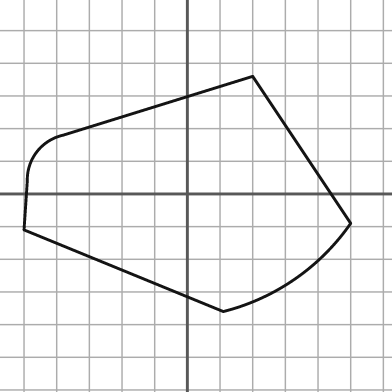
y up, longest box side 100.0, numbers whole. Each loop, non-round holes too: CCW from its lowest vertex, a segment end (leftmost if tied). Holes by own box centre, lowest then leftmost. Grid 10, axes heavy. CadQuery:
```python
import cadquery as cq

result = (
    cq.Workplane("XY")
    .moveTo(11.0, -36.0)
    .threePointArc((33.0, -26.0), (50.0, -9.0))
    .lineTo(20.0, 36.0)
    .lineTo(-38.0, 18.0)
    .threePointArc((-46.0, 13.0), (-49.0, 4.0))
    .lineTo(-50.0, -11.0)
    .close()
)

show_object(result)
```